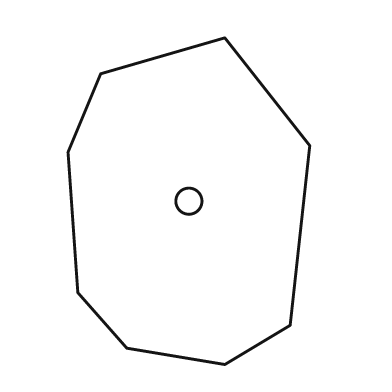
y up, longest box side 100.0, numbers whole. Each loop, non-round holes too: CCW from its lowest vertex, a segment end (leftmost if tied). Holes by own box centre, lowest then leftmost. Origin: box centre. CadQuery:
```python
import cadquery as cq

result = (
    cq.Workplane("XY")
    .moveTo(11.0, -50.0)
    .lineTo(31.0, -38.0)
    .lineTo(37.0, 17.0)
    .lineTo(11.0, 50.0)
    .lineTo(-27.0, 39.0)
    .lineTo(-37.0, 15.0)
    .lineTo(-34.0, -28.0)
    .lineTo(-19.0, -45.0)
    .close()
    .moveTo(0.0, 0.0)
    .circle(4.0)
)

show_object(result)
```